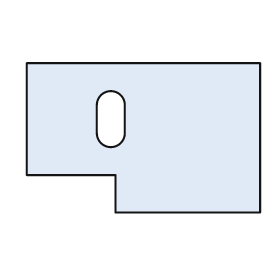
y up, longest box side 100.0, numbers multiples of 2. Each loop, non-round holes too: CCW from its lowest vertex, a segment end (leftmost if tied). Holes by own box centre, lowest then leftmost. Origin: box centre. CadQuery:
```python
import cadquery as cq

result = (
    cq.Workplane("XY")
    .moveTo(-12.0, -32.0)
    .lineTo(50.0, -32.0)
    .lineTo(50.0, 32.0)
    .lineTo(-50.0, 32.0)
    .lineTo(-50.0, -16.0)
    .lineTo(-12.0, -16.0)
    .close()
    .moveTo(-20.0, 2.0)
    .threePointArc((-14.0, -4.0), (-8.0, 2.0))
    .lineTo(-8.0, 14.0)
    .threePointArc((-14.0, 20.0), (-20.0, 14.0))
    .close()
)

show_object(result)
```